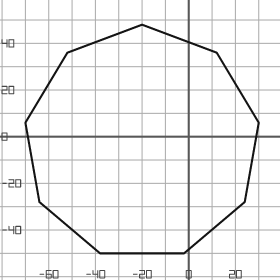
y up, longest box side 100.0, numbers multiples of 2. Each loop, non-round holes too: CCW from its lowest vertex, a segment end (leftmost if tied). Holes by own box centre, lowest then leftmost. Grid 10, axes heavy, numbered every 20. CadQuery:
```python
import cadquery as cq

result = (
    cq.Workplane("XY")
    .moveTo(-38.0, -50.0)
    .lineTo(-2.0, -50.0)
    .lineTo(24.0, -28.0)
    .lineTo(30.0, 6.0)
    .lineTo(12.0, 36.0)
    .lineTo(-20.0, 48.0)
    .lineTo(-52.0, 36.0)
    .lineTo(-70.0, 6.0)
    .lineTo(-64.0, -28.0)
    .close()
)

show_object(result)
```